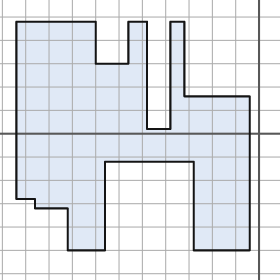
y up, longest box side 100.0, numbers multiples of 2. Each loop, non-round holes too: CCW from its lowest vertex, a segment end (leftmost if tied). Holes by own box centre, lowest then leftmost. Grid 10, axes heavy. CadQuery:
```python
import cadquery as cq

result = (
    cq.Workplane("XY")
    .moveTo(-82.0, -50.0)
    .lineTo(-66.0, -50.0)
    .lineTo(-66.0, -12.0)
    .lineTo(-28.0, -12.0)
    .lineTo(-28.0, -50.0)
    .lineTo(-4.0, -50.0)
    .lineTo(-4.0, 16.0)
    .lineTo(-32.0, 16.0)
    .lineTo(-32.0, 48.0)
    .lineTo(-38.0, 48.0)
    .lineTo(-38.0, 2.0)
    .lineTo(-48.0, 2.0)
    .lineTo(-48.0, 48.0)
    .lineTo(-56.0, 48.0)
    .lineTo(-56.0, 30.0)
    .lineTo(-70.0, 30.0)
    .lineTo(-70.0, 48.0)
    .lineTo(-104.0, 48.0)
    .lineTo(-104.0, -28.0)
    .lineTo(-96.0, -28.0)
    .lineTo(-96.0, -32.0)
    .lineTo(-82.0, -32.0)
    .close()
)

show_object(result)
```